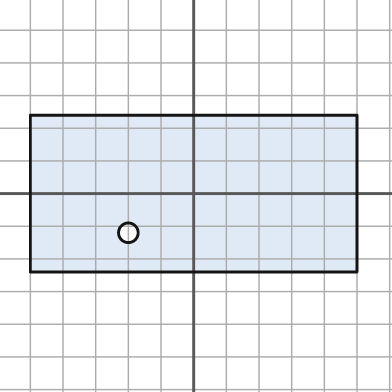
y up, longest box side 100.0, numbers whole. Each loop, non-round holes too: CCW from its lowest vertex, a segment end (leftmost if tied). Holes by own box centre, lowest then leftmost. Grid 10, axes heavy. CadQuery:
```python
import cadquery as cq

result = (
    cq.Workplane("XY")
    .moveTo(-50.0, -24.0)
    .lineTo(50.0, -24.0)
    .lineTo(50.0, 24.0)
    .lineTo(-50.0, 24.0)
    .close()
    .moveTo(-20.0, -12.0)
    .circle(3.0)
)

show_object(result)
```